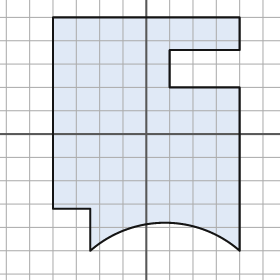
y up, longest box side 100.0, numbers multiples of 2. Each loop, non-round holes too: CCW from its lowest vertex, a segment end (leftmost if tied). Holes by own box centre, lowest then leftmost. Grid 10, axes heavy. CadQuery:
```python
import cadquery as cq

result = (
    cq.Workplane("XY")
    .moveTo(-24.0, -50.0)
    .threePointArc((8.0, -38.0), (40.0, -50.0))
    .lineTo(40.0, 20.0)
    .lineTo(10.0, 20.0)
    .lineTo(10.0, 36.0)
    .lineTo(40.0, 36.0)
    .lineTo(40.0, 50.0)
    .lineTo(-40.0, 50.0)
    .lineTo(-40.0, -32.0)
    .lineTo(-24.0, -32.0)
    .close()
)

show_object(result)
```